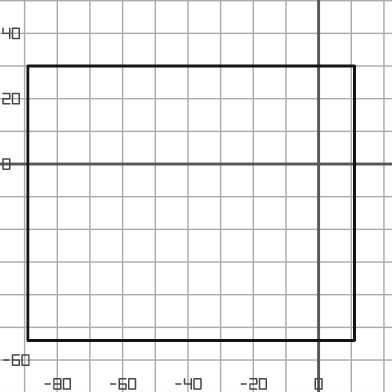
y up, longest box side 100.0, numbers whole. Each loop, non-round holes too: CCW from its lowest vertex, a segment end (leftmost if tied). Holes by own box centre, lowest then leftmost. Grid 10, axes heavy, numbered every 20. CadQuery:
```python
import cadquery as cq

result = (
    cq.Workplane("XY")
    .moveTo(-89.0, -54.0)
    .lineTo(11.0, -54.0)
    .lineTo(11.0, 30.0)
    .lineTo(-89.0, 30.0)
    .close()
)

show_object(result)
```